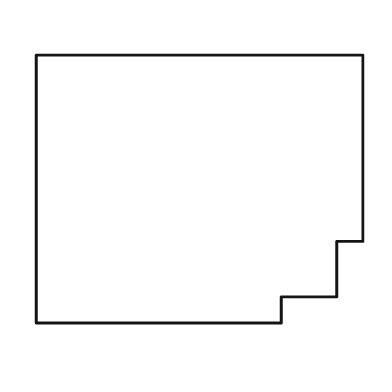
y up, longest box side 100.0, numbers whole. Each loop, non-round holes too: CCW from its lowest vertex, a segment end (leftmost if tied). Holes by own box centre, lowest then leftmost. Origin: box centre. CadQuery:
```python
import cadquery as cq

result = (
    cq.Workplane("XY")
    .moveTo(-50.0, -41.0)
    .lineTo(25.0, -41.0)
    .lineTo(25.0, -33.0)
    .lineTo(42.0, -33.0)
    .lineTo(42.0, -16.0)
    .lineTo(50.0, -16.0)
    .lineTo(50.0, 41.0)
    .lineTo(-50.0, 41.0)
    .close()
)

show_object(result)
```